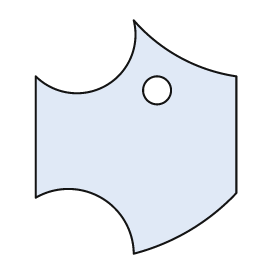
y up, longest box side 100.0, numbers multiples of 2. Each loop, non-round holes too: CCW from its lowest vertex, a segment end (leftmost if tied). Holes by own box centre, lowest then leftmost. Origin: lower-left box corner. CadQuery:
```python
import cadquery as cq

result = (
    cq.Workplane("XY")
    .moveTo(42.0, 0.0)
    .threePointArc((66.0, 10.0), (86.0, 26.0))
    .lineTo(86.0, 76.0)
    .threePointArc((62.0, 84.0), (42.0, 100.0))
    .threePointArc((30.0, 72.0), (0.0, 76.0))
    .lineTo(0.0, 24.0)
    .threePointArc((28.0, 24.0), (42.0, 0.0))
    .close()
    .moveTo(52.0, 70.0)
    .circle(6.0)
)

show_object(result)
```